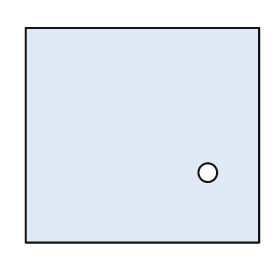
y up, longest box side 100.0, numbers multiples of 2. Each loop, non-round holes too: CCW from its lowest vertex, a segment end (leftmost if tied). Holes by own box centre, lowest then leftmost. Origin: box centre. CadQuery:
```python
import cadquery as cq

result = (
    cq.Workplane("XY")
    .moveTo(-50.0, -46.0)
    .lineTo(50.0, -46.0)
    .lineTo(50.0, 46.0)
    .lineTo(-50.0, 46.0)
    .close()
    .moveTo(28.0, -16.0)
    .circle(4.0)
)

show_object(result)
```